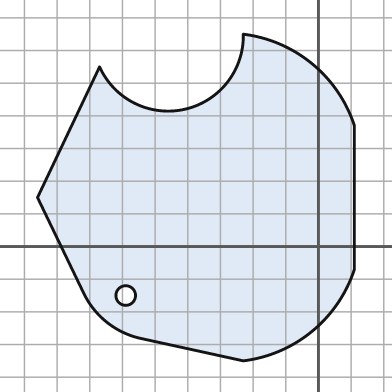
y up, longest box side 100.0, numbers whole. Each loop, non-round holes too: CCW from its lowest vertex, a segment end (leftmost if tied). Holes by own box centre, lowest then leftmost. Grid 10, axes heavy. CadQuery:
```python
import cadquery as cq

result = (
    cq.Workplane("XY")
    .moveTo(-23.0, -35.0)
    .threePointArc((-2.0, -26.0), (11.0, -7.0))
    .lineTo(11.0, 37.0)
    .threePointArc((-2.0, 56.0), (-23.0, 65.0))
    .threePointArc((-41.0, 42.0), (-67.0, 55.0))
    .lineTo(-86.0, 15.0)
    .lineTo(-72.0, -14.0)
    .threePointArc((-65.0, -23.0), (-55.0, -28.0))
    .close()
    .moveTo(-59.0, -15.0)
    .circle(3.0)
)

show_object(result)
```